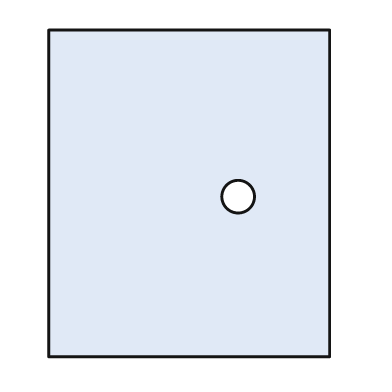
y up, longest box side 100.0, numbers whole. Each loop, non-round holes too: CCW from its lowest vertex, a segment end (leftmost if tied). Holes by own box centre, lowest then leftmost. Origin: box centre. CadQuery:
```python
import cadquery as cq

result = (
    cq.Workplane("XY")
    .moveTo(-43.0, -50.0)
    .lineTo(43.0, -50.0)
    .lineTo(43.0, 50.0)
    .lineTo(-43.0, 50.0)
    .close()
    .moveTo(15.0, -1.0)
    .circle(5.0)
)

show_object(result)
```